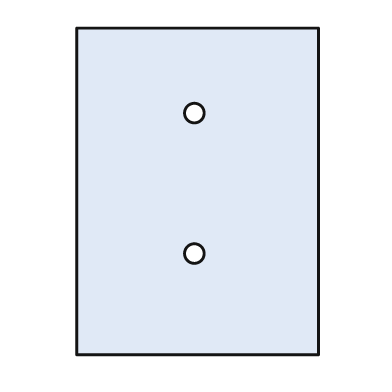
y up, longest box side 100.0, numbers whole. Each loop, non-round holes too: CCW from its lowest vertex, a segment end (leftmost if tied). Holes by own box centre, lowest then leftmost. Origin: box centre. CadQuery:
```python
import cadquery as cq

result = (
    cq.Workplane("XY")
    .moveTo(-37.0, -50.0)
    .lineTo(37.0, -50.0)
    .lineTo(37.0, 50.0)
    .lineTo(-37.0, 50.0)
    .close()
    .moveTo(-1.0, -19.0)
    .circle(3.0)
    .moveTo(-1.0, 24.0)
    .circle(3.0)
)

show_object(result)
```